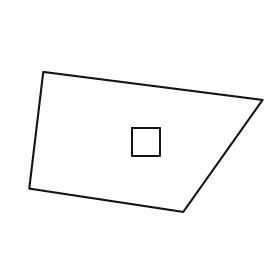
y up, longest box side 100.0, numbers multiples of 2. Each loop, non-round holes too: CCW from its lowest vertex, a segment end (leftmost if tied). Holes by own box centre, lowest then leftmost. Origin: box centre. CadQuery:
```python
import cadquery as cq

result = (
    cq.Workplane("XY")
    .moveTo(16.0, -30.0)
    .lineTo(50.0, 18.0)
    .lineTo(-44.0, 30.0)
    .lineTo(-50.0, -20.0)
    .close()
    .moveTo(-6.0, -6.0)
    .lineTo(6.0, -6.0)
    .lineTo(6.0, 6.0)
    .lineTo(-6.0, 6.0)
    .close()
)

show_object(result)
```